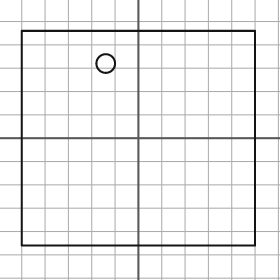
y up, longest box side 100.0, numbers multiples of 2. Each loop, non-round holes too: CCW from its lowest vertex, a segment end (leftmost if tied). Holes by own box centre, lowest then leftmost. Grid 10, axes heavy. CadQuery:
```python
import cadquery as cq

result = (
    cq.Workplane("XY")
    .moveTo(-50.0, -46.0)
    .lineTo(50.0, -46.0)
    .lineTo(50.0, 46.0)
    .lineTo(-50.0, 46.0)
    .close()
    .moveTo(-14.0, 32.0)
    .circle(4.0)
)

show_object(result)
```